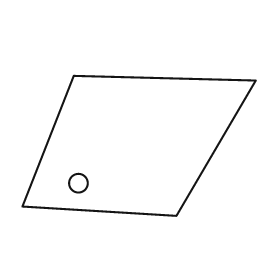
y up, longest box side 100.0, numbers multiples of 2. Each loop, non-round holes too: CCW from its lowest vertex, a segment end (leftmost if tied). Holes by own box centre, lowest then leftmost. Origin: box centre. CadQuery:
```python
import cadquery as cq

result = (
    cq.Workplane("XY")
    .moveTo(16.0, -30.0)
    .lineTo(50.0, 28.0)
    .lineTo(-28.0, 30.0)
    .lineTo(-50.0, -26.0)
    .close()
    .moveTo(-26.0, -16.0)
    .circle(4.0)
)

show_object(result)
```